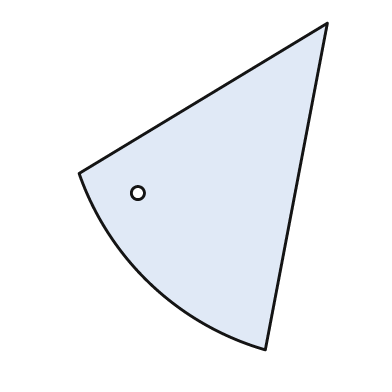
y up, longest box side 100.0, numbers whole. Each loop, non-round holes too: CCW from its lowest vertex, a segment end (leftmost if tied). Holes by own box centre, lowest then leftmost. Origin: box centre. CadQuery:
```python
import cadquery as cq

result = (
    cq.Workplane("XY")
    .moveTo(19.0, -50.0)
    .lineTo(38.0, 50.0)
    .lineTo(-38.0, 4.0)
    .threePointArc((-16.0, -30.0), (19.0, -50.0))
    .close()
    .moveTo(-20.0, -2.0)
    .circle(2.0)
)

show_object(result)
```